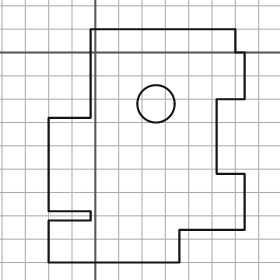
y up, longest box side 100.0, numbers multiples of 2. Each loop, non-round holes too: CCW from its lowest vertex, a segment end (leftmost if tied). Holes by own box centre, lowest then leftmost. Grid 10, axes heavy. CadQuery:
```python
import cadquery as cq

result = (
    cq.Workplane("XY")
    .moveTo(-20.0, -90.0)
    .lineTo(36.0, -90.0)
    .lineTo(36.0, -76.0)
    .lineTo(64.0, -76.0)
    .lineTo(64.0, -52.0)
    .lineTo(52.0, -52.0)
    .lineTo(52.0, -20.0)
    .lineTo(64.0, -20.0)
    .lineTo(64.0, 0.0)
    .lineTo(60.0, 0.0)
    .lineTo(60.0, 10.0)
    .lineTo(-2.0, 10.0)
    .lineTo(-2.0, -28.0)
    .lineTo(-20.0, -28.0)
    .lineTo(-20.0, -68.0)
    .lineTo(-2.0, -68.0)
    .lineTo(-2.0, -72.0)
    .lineTo(-20.0, -72.0)
    .close()
    .moveTo(26.0, -22.0)
    .circle(8.0)
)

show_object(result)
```